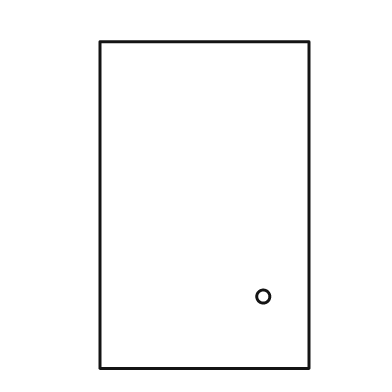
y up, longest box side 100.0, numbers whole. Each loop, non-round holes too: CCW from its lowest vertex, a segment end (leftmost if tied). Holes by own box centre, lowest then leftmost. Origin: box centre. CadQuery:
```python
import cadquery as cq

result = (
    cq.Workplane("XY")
    .moveTo(-32.0, -50.0)
    .lineTo(32.0, -50.0)
    .lineTo(32.0, 50.0)
    .lineTo(-32.0, 50.0)
    .close()
    .moveTo(18.0, -28.0)
    .circle(2.0)
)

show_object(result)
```